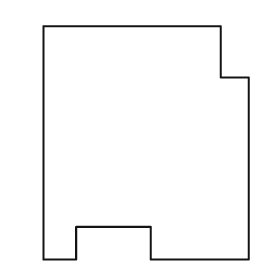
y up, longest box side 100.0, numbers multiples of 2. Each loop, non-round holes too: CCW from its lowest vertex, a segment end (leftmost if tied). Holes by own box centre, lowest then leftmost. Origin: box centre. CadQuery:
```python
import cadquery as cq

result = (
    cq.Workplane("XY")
    .moveTo(-44.0, -50.0)
    .lineTo(-30.0, -50.0)
    .lineTo(-30.0, -36.0)
    .lineTo(2.0, -36.0)
    .lineTo(2.0, -50.0)
    .lineTo(44.0, -50.0)
    .lineTo(44.0, 28.0)
    .lineTo(32.0, 28.0)
    .lineTo(32.0, 50.0)
    .lineTo(-44.0, 50.0)
    .close()
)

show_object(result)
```